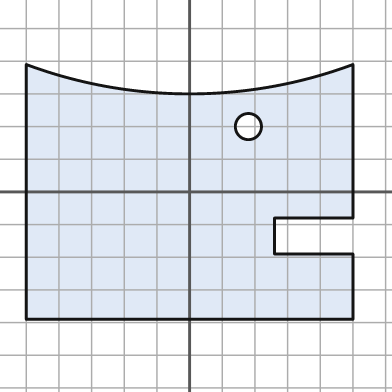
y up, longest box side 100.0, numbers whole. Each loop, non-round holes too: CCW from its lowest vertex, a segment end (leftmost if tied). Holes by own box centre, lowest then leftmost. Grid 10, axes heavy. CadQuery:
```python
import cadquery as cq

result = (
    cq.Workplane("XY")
    .moveTo(-50.0, -39.0)
    .lineTo(50.0, -39.0)
    .lineTo(50.0, -19.0)
    .lineTo(26.0, -19.0)
    .lineTo(26.0, -8.0)
    .lineTo(50.0, -8.0)
    .lineTo(50.0, 39.0)
    .threePointArc((0.0, 30.0), (-50.0, 39.0))
    .close()
    .moveTo(18.0, 20.0)
    .circle(4.0)
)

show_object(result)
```